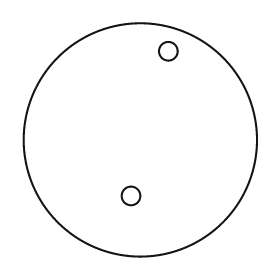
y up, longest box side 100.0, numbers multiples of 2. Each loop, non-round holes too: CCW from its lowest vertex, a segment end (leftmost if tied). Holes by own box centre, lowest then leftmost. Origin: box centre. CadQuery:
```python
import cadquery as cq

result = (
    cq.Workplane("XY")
    .moveTo(0.0, 0.0)
    .circle(50.0)
    .moveTo(-4.0, -24.0)
    .circle(4.0)
    .moveTo(12.0, 38.0)
    .circle(4.0)
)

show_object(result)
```